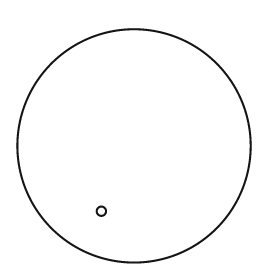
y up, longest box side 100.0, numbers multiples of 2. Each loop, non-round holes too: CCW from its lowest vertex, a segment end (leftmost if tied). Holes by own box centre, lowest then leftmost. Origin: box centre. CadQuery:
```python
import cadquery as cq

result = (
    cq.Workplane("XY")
    .moveTo(0.0, 0.0)
    .circle(50.0)
    .moveTo(-14.0, -28.0)
    .circle(2.0)
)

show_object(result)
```